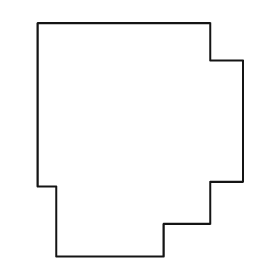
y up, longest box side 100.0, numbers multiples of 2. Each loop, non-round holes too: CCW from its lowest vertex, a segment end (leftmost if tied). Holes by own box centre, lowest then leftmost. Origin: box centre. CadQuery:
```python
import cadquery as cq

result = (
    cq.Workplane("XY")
    .moveTo(-36.0, -50.0)
    .lineTo(10.0, -50.0)
    .lineTo(10.0, -36.0)
    .lineTo(30.0, -36.0)
    .lineTo(30.0, -18.0)
    .lineTo(44.0, -18.0)
    .lineTo(44.0, 34.0)
    .lineTo(30.0, 34.0)
    .lineTo(30.0, 50.0)
    .lineTo(-44.0, 50.0)
    .lineTo(-44.0, -20.0)
    .lineTo(-36.0, -20.0)
    .close()
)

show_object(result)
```